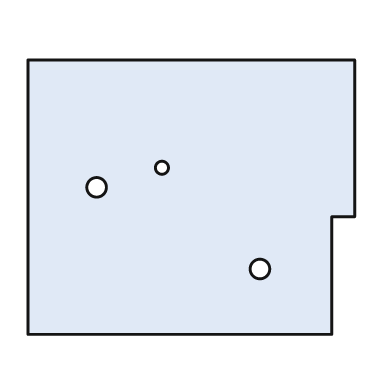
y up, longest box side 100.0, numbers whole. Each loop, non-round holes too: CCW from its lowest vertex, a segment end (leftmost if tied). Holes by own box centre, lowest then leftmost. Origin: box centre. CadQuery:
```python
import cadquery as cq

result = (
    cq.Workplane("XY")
    .moveTo(-50.0, -42.0)
    .lineTo(43.0, -42.0)
    .lineTo(43.0, -6.0)
    .lineTo(50.0, -6.0)
    .lineTo(50.0, 42.0)
    .lineTo(-50.0, 42.0)
    .close()
    .moveTo(21.0, -22.0)
    .circle(3.0)
    .moveTo(-29.0, 3.0)
    .circle(3.0)
    .moveTo(-9.0, 9.0)
    .circle(2.0)
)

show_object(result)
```